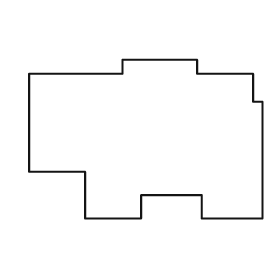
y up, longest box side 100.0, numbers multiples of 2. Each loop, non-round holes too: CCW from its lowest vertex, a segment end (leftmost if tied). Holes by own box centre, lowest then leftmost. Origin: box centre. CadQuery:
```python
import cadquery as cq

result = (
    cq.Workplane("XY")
    .moveTo(-26.0, -34.0)
    .lineTo(-2.0, -34.0)
    .lineTo(-2.0, -24.0)
    .lineTo(24.0, -24.0)
    .lineTo(24.0, -34.0)
    .lineTo(50.0, -34.0)
    .lineTo(50.0, 16.0)
    .lineTo(46.0, 16.0)
    .lineTo(46.0, 28.0)
    .lineTo(22.0, 28.0)
    .lineTo(22.0, 34.0)
    .lineTo(-10.0, 34.0)
    .lineTo(-10.0, 28.0)
    .lineTo(-50.0, 28.0)
    .lineTo(-50.0, -14.0)
    .lineTo(-26.0, -14.0)
    .close()
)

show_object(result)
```